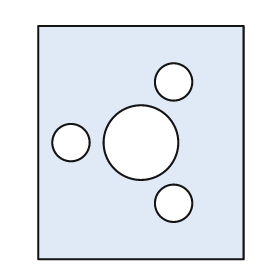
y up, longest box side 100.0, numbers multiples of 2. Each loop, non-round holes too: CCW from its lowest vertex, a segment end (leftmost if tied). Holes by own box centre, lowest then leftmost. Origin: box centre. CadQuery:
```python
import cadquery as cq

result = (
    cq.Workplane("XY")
    .moveTo(-44.0, -50.0)
    .lineTo(44.0, -50.0)
    .lineTo(44.0, 50.0)
    .lineTo(-44.0, 50.0)
    .close()
    .moveTo(14.0, -26.0)
    .circle(8.0)
    .moveTo(-30.0, 0.0)
    .circle(8.0)
    .moveTo(0.0, 0.0)
    .circle(16.0)
    .moveTo(14.0, 26.0)
    .circle(8.0)
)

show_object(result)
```